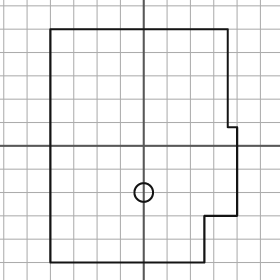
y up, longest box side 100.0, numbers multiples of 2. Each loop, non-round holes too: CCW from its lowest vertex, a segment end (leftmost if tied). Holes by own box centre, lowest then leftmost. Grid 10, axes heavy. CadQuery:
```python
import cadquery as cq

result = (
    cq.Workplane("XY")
    .moveTo(-40.0, -50.0)
    .lineTo(26.0, -50.0)
    .lineTo(26.0, -30.0)
    .lineTo(40.0, -30.0)
    .lineTo(40.0, 8.0)
    .lineTo(36.0, 8.0)
    .lineTo(36.0, 50.0)
    .lineTo(-40.0, 50.0)
    .close()
    .moveTo(0.0, -20.0)
    .circle(4.0)
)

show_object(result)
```